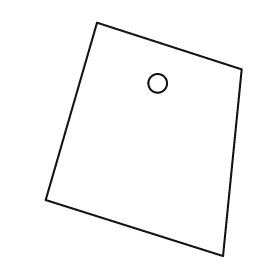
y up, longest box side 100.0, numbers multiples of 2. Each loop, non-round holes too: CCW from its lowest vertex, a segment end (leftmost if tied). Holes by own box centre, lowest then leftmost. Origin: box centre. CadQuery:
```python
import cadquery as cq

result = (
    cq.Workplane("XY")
    .moveTo(34.0, -50.0)
    .lineTo(42.0, 30.0)
    .lineTo(-20.0, 50.0)
    .lineTo(-42.0, -26.0)
    .close()
    .moveTo(6.0, 24.0)
    .circle(4.0)
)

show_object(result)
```